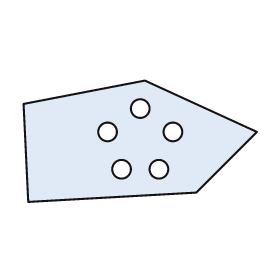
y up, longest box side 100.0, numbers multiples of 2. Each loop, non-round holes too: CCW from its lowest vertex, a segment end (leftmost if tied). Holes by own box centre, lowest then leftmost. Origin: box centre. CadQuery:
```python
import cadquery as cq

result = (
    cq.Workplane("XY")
    .moveTo(-48.0, -26.0)
    .lineTo(24.0, -22.0)
    .lineTo(50.0, 4.0)
    .lineTo(2.0, 26.0)
    .lineTo(-50.0, 16.0)
    .close()
    .moveTo(-8.0, -12.0)
    .circle(4.0)
    .moveTo(8.0, -12.0)
    .circle(4.0)
    .moveTo(-14.0, 4.0)
    .circle(4.0)
    .moveTo(14.0, 4.0)
    .circle(4.0)
    .moveTo(0.0, 14.0)
    .circle(4.0)
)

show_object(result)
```